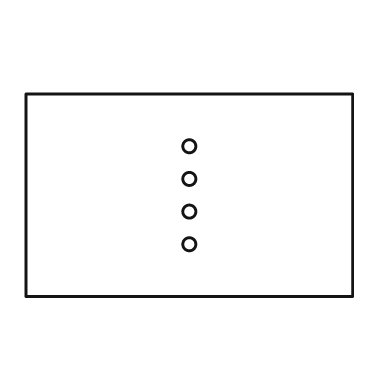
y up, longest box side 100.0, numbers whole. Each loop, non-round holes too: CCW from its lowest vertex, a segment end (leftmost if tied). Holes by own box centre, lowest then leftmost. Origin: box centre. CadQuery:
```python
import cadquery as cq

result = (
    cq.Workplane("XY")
    .moveTo(-50.0, -31.0)
    .lineTo(50.0, -31.0)
    .lineTo(50.0, 31.0)
    .lineTo(-50.0, 31.0)
    .close()
    .moveTo(0.0, -15.0)
    .circle(2.0)
    .moveTo(0.0, -5.0)
    .circle(2.0)
    .moveTo(0.0, 5.0)
    .circle(2.0)
    .moveTo(0.0, 15.0)
    .circle(2.0)
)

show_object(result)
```